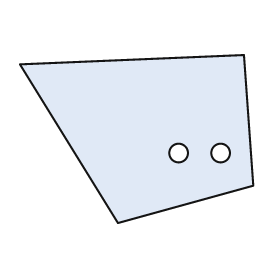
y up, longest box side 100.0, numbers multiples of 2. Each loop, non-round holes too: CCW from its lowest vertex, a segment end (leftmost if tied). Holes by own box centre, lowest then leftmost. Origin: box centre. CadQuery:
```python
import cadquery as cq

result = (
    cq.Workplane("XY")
    .moveTo(-8.0, -36.0)
    .lineTo(50.0, -20.0)
    .lineTo(46.0, 36.0)
    .lineTo(-50.0, 32.0)
    .close()
    .moveTo(18.0, -6.0)
    .circle(4.0)
    .moveTo(36.0, -6.0)
    .circle(4.0)
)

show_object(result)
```